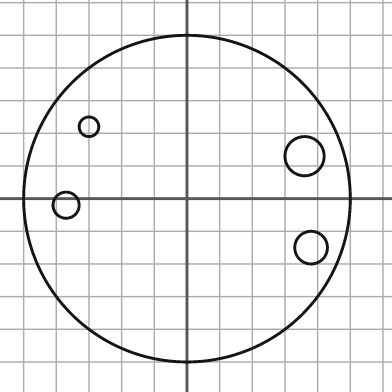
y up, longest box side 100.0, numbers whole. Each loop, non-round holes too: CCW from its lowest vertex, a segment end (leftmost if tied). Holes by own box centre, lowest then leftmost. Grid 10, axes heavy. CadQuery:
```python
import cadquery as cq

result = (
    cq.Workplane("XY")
    .moveTo(0.0, 0.0)
    .circle(50.0)
    .moveTo(38.0, -15.0)
    .circle(5.0)
    .moveTo(-37.0, -2.0)
    .circle(4.0)
    .moveTo(36.0, 13.0)
    .circle(6.0)
    .moveTo(-30.0, 22.0)
    .circle(3.0)
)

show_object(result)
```